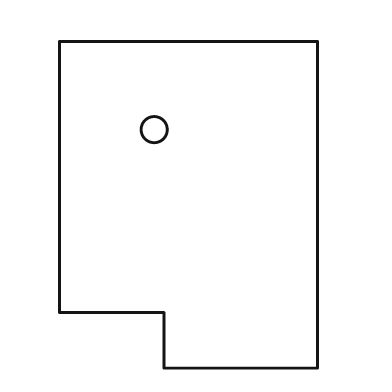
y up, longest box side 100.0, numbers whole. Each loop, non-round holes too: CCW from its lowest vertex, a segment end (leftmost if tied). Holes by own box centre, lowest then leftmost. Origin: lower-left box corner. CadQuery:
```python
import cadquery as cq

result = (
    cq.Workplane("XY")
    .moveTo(32.0, 0.0)
    .lineTo(79.0, 0.0)
    .lineTo(79.0, 100.0)
    .lineTo(0.0, 100.0)
    .lineTo(0.0, 17.0)
    .lineTo(32.0, 17.0)
    .close()
    .moveTo(29.0, 73.0)
    .circle(4.0)
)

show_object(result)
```